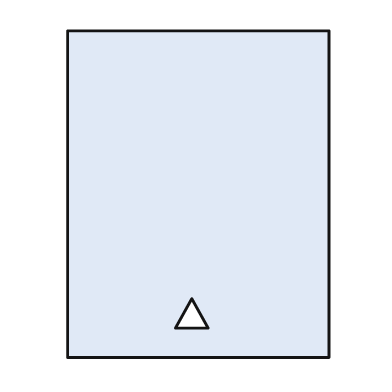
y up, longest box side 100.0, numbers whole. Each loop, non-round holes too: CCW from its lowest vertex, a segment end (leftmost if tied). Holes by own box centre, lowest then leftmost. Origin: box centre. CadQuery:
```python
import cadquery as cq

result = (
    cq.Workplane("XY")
    .moveTo(-40.0, -50.0)
    .lineTo(40.0, -50.0)
    .lineTo(40.0, 50.0)
    .lineTo(-40.0, 50.0)
    .close()
    .moveTo(-7.0, -41.0)
    .lineTo(3.0, -41.0)
    .lineTo(-2.0, -32.0)
    .close()
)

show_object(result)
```